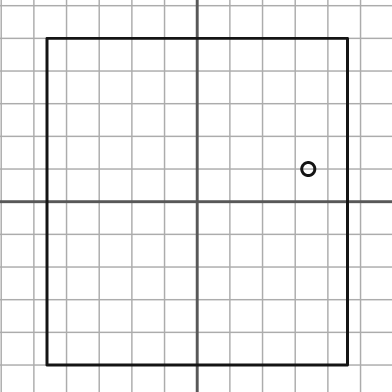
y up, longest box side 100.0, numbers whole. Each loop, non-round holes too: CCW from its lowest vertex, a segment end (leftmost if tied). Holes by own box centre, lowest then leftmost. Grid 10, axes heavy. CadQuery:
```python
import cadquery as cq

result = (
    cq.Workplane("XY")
    .moveTo(-46.0, -50.0)
    .lineTo(46.0, -50.0)
    .lineTo(46.0, 50.0)
    .lineTo(-46.0, 50.0)
    .close()
    .moveTo(34.0, 10.0)
    .circle(2.0)
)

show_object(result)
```